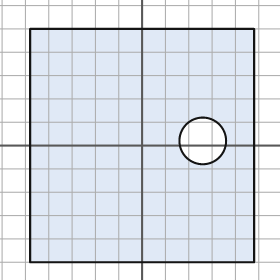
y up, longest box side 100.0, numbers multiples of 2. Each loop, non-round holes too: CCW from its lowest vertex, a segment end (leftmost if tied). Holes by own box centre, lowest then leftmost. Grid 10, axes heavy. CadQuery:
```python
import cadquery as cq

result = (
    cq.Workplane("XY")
    .moveTo(-48.0, -50.0)
    .lineTo(48.0, -50.0)
    .lineTo(48.0, 50.0)
    .lineTo(-48.0, 50.0)
    .close()
    .moveTo(26.0, 2.0)
    .circle(10.0)
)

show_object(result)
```